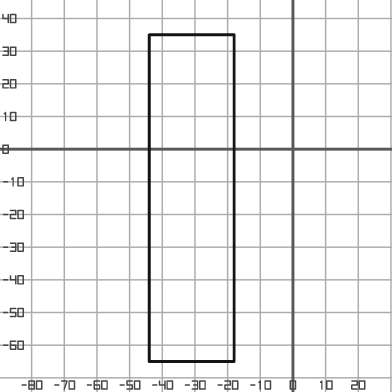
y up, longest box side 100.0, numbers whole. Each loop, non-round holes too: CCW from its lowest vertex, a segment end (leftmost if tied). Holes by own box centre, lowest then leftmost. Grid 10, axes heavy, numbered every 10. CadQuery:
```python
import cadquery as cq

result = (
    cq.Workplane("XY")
    .moveTo(-44.0, -65.0)
    .lineTo(-18.0, -65.0)
    .lineTo(-18.0, 35.0)
    .lineTo(-44.0, 35.0)
    .close()
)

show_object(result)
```